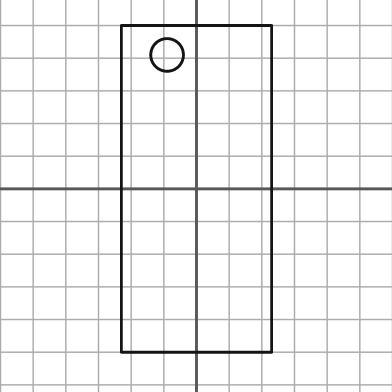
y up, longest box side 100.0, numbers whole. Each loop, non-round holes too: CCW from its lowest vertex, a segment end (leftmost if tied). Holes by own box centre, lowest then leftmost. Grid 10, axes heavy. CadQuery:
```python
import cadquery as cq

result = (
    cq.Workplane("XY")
    .moveTo(-23.0, -50.0)
    .lineTo(23.0, -50.0)
    .lineTo(23.0, 50.0)
    .lineTo(-23.0, 50.0)
    .close()
    .moveTo(-9.0, 41.0)
    .circle(5.0)
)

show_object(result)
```